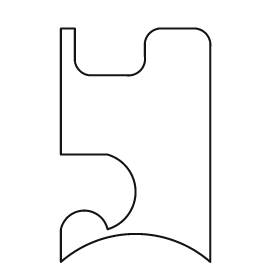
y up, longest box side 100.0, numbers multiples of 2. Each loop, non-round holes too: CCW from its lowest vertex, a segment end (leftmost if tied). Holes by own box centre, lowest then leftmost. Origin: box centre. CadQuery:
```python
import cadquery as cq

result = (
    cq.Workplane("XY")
    .moveTo(-32.0, -50.0)
    .threePointArc((0.0, -38.0), (32.0, -50.0))
    .lineTo(32.0, 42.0)
    .threePointArc((30.0, 48.0), (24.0, 50.0))
    .lineTo(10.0, 50.0)
    .threePointArc((6.0, 48.0), (4.0, 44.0))
    .lineTo(4.0, 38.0)
    .threePointArc((2.0, 32.0), (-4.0, 30.0))
    .lineTo(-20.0, 30.0)
    .threePointArc((-24.0, 32.0), (-26.0, 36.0))
    .lineTo(-26.0, 50.0)
    .lineTo(-32.0, 50.0)
    .lineTo(-32.0, -4.0)
    .lineTo(-12.0, -4.0)
    .threePointArc((0.0, -20.0), (-12.0, -36.0))
    .threePointArc((-22.0, -28.0), (-32.0, -36.0))
    .close()
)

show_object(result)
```